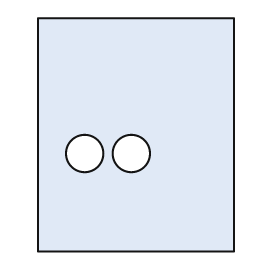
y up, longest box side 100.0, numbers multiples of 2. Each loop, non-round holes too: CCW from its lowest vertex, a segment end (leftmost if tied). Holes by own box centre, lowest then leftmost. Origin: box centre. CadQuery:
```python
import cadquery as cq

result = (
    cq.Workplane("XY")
    .moveTo(-42.0, -50.0)
    .lineTo(42.0, -50.0)
    .lineTo(42.0, 50.0)
    .lineTo(-42.0, 50.0)
    .close()
    .moveTo(-22.0, -8.0)
    .circle(8.0)
    .moveTo(-2.0, -8.0)
    .circle(8.0)
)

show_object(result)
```